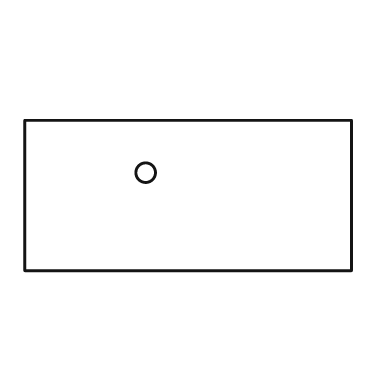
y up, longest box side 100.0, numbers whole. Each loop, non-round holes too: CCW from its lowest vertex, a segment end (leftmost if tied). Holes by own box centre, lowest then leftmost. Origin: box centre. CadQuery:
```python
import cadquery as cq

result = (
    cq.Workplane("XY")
    .moveTo(-50.0, -23.0)
    .lineTo(50.0, -23.0)
    .lineTo(50.0, 23.0)
    .lineTo(-50.0, 23.0)
    .close()
    .moveTo(-13.0, 7.0)
    .circle(3.0)
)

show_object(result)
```